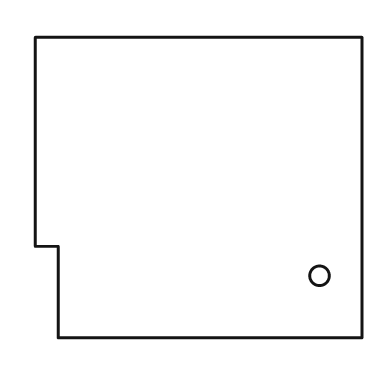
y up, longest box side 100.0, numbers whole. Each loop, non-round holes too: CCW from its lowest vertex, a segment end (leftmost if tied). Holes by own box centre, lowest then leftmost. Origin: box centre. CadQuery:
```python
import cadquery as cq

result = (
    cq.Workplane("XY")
    .moveTo(-43.0, -46.0)
    .lineTo(50.0, -46.0)
    .lineTo(50.0, 46.0)
    .lineTo(-50.0, 46.0)
    .lineTo(-50.0, -18.0)
    .lineTo(-43.0, -18.0)
    .close()
    .moveTo(37.0, -27.0)
    .circle(3.0)
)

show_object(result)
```